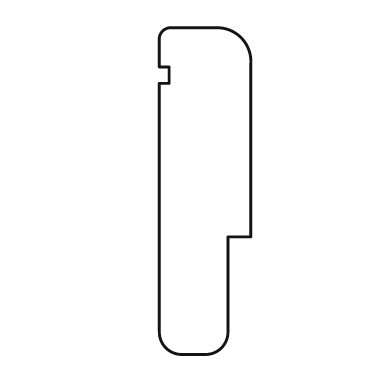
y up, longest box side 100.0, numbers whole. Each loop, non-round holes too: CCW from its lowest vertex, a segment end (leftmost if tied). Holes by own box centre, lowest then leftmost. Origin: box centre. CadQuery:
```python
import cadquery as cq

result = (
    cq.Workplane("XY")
    .moveTo(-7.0, -50.0)
    .lineTo(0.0, -50.0)
    .threePointArc((5.0, -48.0), (7.0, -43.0))
    .lineTo(7.0, -14.0)
    .lineTo(14.0, -14.0)
    .lineTo(14.0, 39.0)
    .threePointArc((11.0, 47.0), (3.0, 50.0))
    .lineTo(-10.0, 50.0)
    .threePointArc((-13.0, 49.0), (-14.0, 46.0))
    .lineTo(-14.0, 38.0)
    .lineTo(-11.0, 38.0)
    .lineTo(-11.0, 33.0)
    .lineTo(-14.0, 33.0)
    .lineTo(-14.0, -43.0)
    .threePointArc((-12.0, -48.0), (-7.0, -50.0))
    .close()
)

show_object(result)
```